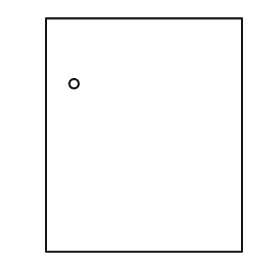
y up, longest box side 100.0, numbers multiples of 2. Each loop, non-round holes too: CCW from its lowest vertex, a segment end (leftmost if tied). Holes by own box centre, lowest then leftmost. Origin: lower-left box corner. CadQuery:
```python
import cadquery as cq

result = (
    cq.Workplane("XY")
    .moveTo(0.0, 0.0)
    .lineTo(84.0, 0.0)
    .lineTo(84.0, 100.0)
    .lineTo(0.0, 100.0)
    .close()
    .moveTo(12.0, 72.0)
    .circle(2.0)
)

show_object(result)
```